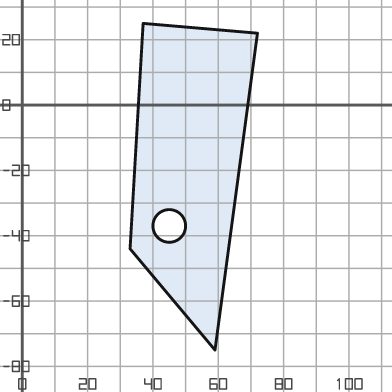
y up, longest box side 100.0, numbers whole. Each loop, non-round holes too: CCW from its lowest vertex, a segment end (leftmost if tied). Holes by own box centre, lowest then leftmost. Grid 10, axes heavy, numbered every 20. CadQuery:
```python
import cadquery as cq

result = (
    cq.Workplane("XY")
    .moveTo(59.0, -75.0)
    .lineTo(72.0, 22.0)
    .lineTo(37.0, 25.0)
    .lineTo(33.0, -44.0)
    .close()
    .moveTo(45.0, -37.0)
    .circle(5.0)
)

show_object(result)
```